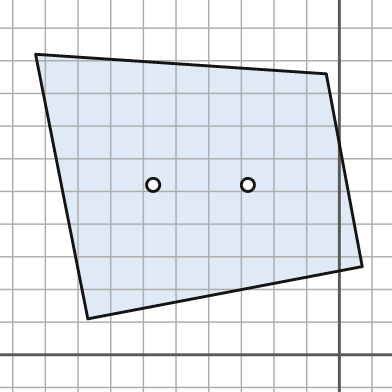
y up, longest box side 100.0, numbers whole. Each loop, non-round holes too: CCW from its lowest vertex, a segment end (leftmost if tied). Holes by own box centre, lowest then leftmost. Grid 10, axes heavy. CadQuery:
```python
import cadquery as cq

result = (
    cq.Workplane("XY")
    .moveTo(-77.0, 11.0)
    .lineTo(7.0, 27.0)
    .lineTo(-4.0, 86.0)
    .lineTo(-93.0, 92.0)
    .close()
    .moveTo(-57.0, 52.0)
    .circle(2.0)
    .moveTo(-28.0, 52.0)
    .circle(2.0)
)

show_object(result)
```